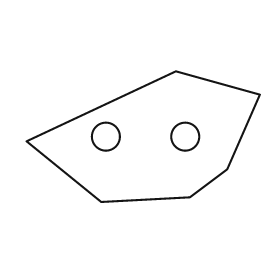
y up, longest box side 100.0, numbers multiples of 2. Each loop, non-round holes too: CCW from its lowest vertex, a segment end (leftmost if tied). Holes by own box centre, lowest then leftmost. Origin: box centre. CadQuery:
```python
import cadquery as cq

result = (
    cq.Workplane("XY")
    .moveTo(-18.0, -28.0)
    .lineTo(20.0, -26.0)
    .lineTo(36.0, -14.0)
    .lineTo(50.0, 18.0)
    .lineTo(14.0, 28.0)
    .lineTo(-50.0, -2.0)
    .close()
    .moveTo(-16.0, 0.0)
    .circle(6.0)
    .moveTo(18.0, 0.0)
    .circle(6.0)
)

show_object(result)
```